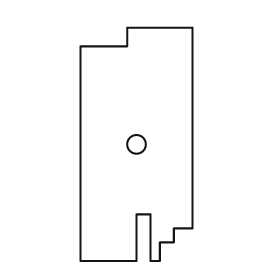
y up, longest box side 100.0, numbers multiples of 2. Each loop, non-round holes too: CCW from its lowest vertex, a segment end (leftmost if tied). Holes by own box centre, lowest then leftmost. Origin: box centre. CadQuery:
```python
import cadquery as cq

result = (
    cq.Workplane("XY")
    .moveTo(-24.0, -50.0)
    .lineTo(0.0, -50.0)
    .lineTo(0.0, -30.0)
    .lineTo(6.0, -30.0)
    .lineTo(6.0, -50.0)
    .lineTo(10.0, -50.0)
    .lineTo(10.0, -42.0)
    .lineTo(16.0, -42.0)
    .lineTo(16.0, -36.0)
    .lineTo(24.0, -36.0)
    .lineTo(24.0, 50.0)
    .lineTo(-4.0, 50.0)
    .lineTo(-4.0, 42.0)
    .lineTo(-24.0, 42.0)
    .close()
    .moveTo(0.0, 0.0)
    .circle(4.0)
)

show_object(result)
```